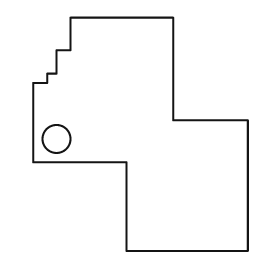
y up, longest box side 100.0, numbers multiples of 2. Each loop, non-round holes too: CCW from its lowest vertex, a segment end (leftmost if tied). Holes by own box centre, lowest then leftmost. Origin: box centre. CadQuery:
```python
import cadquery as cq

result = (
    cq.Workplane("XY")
    .moveTo(-6.0, -50.0)
    .lineTo(46.0, -50.0)
    .lineTo(46.0, 6.0)
    .lineTo(14.0, 6.0)
    .lineTo(14.0, 50.0)
    .lineTo(-30.0, 50.0)
    .lineTo(-30.0, 36.0)
    .lineTo(-36.0, 36.0)
    .lineTo(-36.0, 26.0)
    .lineTo(-40.0, 26.0)
    .lineTo(-40.0, 22.0)
    .lineTo(-46.0, 22.0)
    .lineTo(-46.0, -12.0)
    .lineTo(-6.0, -12.0)
    .close()
    .moveTo(-36.0, -2.0)
    .circle(6.0)
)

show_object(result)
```